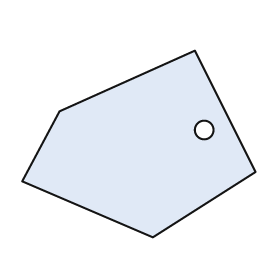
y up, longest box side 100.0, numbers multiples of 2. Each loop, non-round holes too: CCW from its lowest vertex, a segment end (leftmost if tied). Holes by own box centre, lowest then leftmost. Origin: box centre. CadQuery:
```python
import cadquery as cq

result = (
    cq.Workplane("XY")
    .moveTo(6.0, -40.0)
    .lineTo(50.0, -12.0)
    .lineTo(24.0, 40.0)
    .lineTo(-34.0, 14.0)
    .lineTo(-50.0, -16.0)
    .close()
    .moveTo(28.0, 6.0)
    .circle(4.0)
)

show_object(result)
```